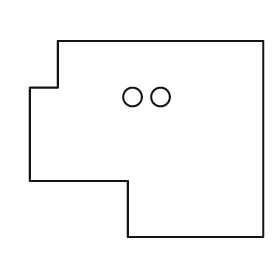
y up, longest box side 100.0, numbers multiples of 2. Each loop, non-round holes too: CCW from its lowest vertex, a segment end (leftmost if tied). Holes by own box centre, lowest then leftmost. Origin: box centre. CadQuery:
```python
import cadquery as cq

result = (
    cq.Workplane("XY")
    .moveTo(-8.0, -42.0)
    .lineTo(50.0, -42.0)
    .lineTo(50.0, 42.0)
    .lineTo(-38.0, 42.0)
    .lineTo(-38.0, 22.0)
    .lineTo(-50.0, 22.0)
    .lineTo(-50.0, -18.0)
    .lineTo(-8.0, -18.0)
    .close()
    .moveTo(-6.0, 18.0)
    .circle(4.0)
    .moveTo(6.0, 18.0)
    .circle(4.0)
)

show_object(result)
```